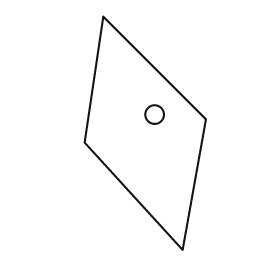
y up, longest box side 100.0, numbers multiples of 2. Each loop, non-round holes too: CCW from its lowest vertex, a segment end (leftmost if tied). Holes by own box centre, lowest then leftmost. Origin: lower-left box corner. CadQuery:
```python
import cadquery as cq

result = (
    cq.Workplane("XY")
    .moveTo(42.0, 0.0)
    .lineTo(52.0, 56.0)
    .lineTo(8.0, 100.0)
    .lineTo(0.0, 46.0)
    .close()
    .moveTo(30.0, 58.0)
    .circle(4.0)
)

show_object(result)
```